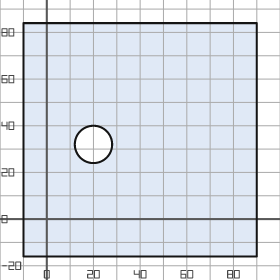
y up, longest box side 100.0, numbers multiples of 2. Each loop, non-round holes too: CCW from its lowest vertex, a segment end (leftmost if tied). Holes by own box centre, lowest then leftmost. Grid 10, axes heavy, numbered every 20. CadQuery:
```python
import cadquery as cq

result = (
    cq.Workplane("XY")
    .moveTo(-10.0, -16.0)
    .lineTo(90.0, -16.0)
    .lineTo(90.0, 84.0)
    .lineTo(-10.0, 84.0)
    .close()
    .moveTo(20.0, 32.0)
    .circle(8.0)
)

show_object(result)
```